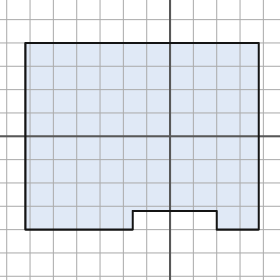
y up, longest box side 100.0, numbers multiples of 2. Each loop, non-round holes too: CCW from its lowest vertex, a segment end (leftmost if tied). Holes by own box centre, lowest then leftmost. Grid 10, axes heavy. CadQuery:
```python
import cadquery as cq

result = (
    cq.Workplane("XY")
    .moveTo(-62.0, -40.0)
    .lineTo(-16.0, -40.0)
    .lineTo(-16.0, -32.0)
    .lineTo(20.0, -32.0)
    .lineTo(20.0, -40.0)
    .lineTo(38.0, -40.0)
    .lineTo(38.0, 40.0)
    .lineTo(-62.0, 40.0)
    .close()
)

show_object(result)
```